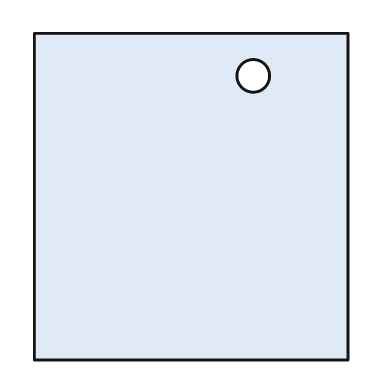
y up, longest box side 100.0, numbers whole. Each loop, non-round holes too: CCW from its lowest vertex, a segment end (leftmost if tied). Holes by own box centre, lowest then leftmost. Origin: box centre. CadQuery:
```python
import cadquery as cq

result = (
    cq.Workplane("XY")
    .moveTo(-48.0, -50.0)
    .lineTo(48.0, -50.0)
    .lineTo(48.0, 50.0)
    .lineTo(-48.0, 50.0)
    .close()
    .moveTo(19.0, 37.0)
    .circle(5.0)
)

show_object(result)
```